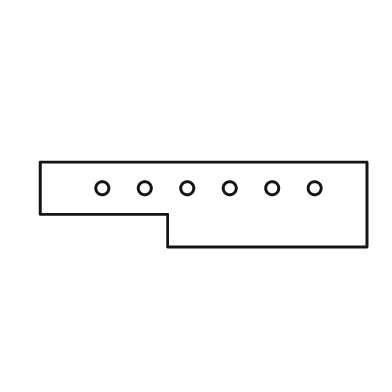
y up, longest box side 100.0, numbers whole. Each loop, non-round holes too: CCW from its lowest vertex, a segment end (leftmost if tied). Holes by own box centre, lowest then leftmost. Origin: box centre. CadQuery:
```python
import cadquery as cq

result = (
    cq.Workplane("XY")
    .moveTo(-11.0, -13.0)
    .lineTo(50.0, -13.0)
    .lineTo(50.0, 13.0)
    .lineTo(-50.0, 13.0)
    .lineTo(-50.0, -3.0)
    .lineTo(-11.0, -3.0)
    .close()
    .moveTo(-31.0, 5.0)
    .circle(2.0)
    .moveTo(-18.0, 5.0)
    .circle(2.0)
    .moveTo(-5.0, 5.0)
    .circle(2.0)
    .moveTo(8.0, 5.0)
    .circle(2.0)
    .moveTo(21.0, 5.0)
    .circle(2.0)
    .moveTo(34.0, 5.0)
    .circle(2.0)
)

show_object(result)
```